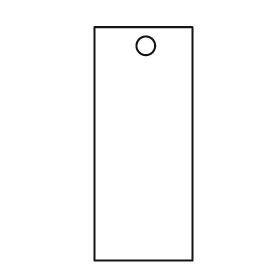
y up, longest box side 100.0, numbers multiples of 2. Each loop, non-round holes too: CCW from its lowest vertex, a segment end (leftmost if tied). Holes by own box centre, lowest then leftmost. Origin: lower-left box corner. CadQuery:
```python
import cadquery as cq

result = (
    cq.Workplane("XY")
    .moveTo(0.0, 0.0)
    .lineTo(42.0, 0.0)
    .lineTo(42.0, 100.0)
    .lineTo(0.0, 100.0)
    .close()
    .moveTo(22.0, 92.0)
    .circle(4.0)
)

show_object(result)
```